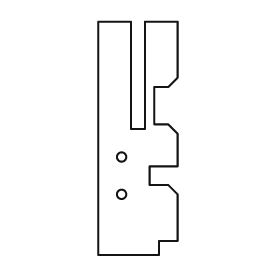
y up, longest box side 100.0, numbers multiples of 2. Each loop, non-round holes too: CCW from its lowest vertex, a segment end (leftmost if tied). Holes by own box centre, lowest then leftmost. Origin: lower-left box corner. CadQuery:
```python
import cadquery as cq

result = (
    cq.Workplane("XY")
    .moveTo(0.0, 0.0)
    .lineTo(26.0, 0.0)
    .lineTo(26.0, 6.0)
    .lineTo(34.0, 6.0)
    .lineTo(34.0, 26.0)
    .lineTo(30.0, 30.0)
    .lineTo(22.0, 30.0)
    .lineTo(22.0, 38.0)
    .lineTo(34.0, 38.0)
    .lineTo(34.0, 52.0)
    .lineTo(30.0, 56.0)
    .lineTo(24.0, 56.0)
    .lineTo(24.0, 72.0)
    .lineTo(30.0, 72.0)
    .lineTo(34.0, 76.0)
    .lineTo(34.0, 100.0)
    .lineTo(20.0, 100.0)
    .lineTo(20.0, 54.0)
    .lineTo(14.0, 54.0)
    .lineTo(14.0, 100.0)
    .lineTo(0.0, 100.0)
    .close()
    .moveTo(10.0, 26.0)
    .circle(2.0)
    .moveTo(10.0, 42.0)
    .circle(2.0)
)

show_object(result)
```